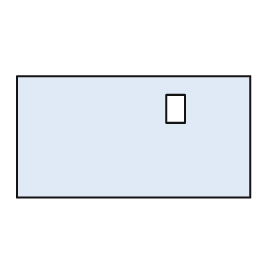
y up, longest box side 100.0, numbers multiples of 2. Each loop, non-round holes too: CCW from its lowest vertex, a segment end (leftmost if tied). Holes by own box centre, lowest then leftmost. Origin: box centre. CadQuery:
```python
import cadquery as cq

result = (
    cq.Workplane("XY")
    .moveTo(-50.0, -26.0)
    .lineTo(50.0, -26.0)
    .lineTo(50.0, 26.0)
    .lineTo(-50.0, 26.0)
    .close()
    .moveTo(14.0, 6.0)
    .lineTo(22.0, 6.0)
    .lineTo(22.0, 18.0)
    .lineTo(14.0, 18.0)
    .close()
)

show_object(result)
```